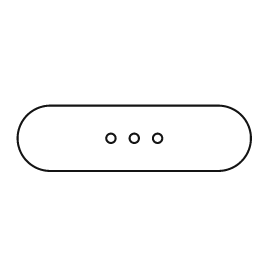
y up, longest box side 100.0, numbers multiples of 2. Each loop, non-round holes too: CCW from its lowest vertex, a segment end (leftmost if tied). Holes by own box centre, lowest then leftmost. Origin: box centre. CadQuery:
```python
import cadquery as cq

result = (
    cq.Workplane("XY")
    .moveTo(-36.0, -14.0)
    .lineTo(36.0, -14.0)
    .threePointArc((50.0, 0.0), (36.0, 14.0))
    .lineTo(-36.0, 14.0)
    .threePointArc((-50.0, 0.0), (-36.0, -14.0))
    .close()
    .moveTo(-10.0, 0.0)
    .circle(2.0)
    .moveTo(0.0, 0.0)
    .circle(2.0)
    .moveTo(10.0, 0.0)
    .circle(2.0)
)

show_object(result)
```